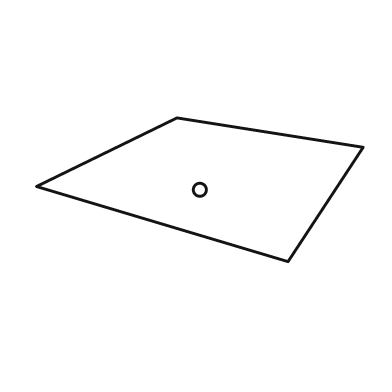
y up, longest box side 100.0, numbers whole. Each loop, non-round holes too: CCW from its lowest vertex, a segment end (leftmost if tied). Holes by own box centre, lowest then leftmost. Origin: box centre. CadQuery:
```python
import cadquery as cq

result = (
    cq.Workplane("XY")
    .moveTo(27.0, -22.0)
    .lineTo(50.0, 13.0)
    .lineTo(-7.0, 22.0)
    .lineTo(-50.0, 1.0)
    .close()
    .moveTo(0.0, 0.0)
    .circle(2.0)
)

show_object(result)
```